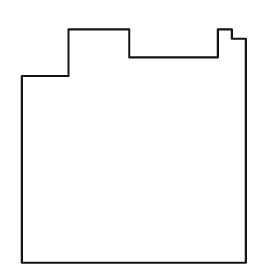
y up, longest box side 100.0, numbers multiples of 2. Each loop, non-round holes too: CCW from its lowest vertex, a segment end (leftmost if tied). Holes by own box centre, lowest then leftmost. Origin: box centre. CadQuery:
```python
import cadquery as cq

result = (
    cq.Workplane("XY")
    .moveTo(-48.0, -50.0)
    .lineTo(48.0, -50.0)
    .lineTo(48.0, 46.0)
    .lineTo(42.0, 46.0)
    .lineTo(42.0, 50.0)
    .lineTo(36.0, 50.0)
    .lineTo(36.0, 38.0)
    .lineTo(-2.0, 38.0)
    .lineTo(-2.0, 50.0)
    .lineTo(-28.0, 50.0)
    .lineTo(-28.0, 30.0)
    .lineTo(-48.0, 30.0)
    .close()
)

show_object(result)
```